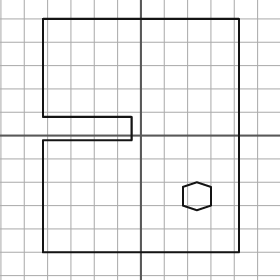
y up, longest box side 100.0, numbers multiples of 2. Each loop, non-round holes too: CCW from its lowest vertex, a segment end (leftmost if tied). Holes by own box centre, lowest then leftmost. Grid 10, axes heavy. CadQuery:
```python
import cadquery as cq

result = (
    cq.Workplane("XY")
    .moveTo(-42.0, -50.0)
    .lineTo(42.0, -50.0)
    .lineTo(42.0, 50.0)
    .lineTo(-42.0, 50.0)
    .lineTo(-42.0, 8.0)
    .lineTo(-4.0, 8.0)
    .lineTo(-4.0, -2.0)
    .lineTo(-42.0, -2.0)
    .close()
    .moveTo(24.0, -32.0)
    .lineTo(30.0, -30.0)
    .lineTo(30.0, -22.0)
    .lineTo(24.0, -20.0)
    .lineTo(18.0, -22.0)
    .lineTo(18.0, -30.0)
    .close()
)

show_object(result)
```